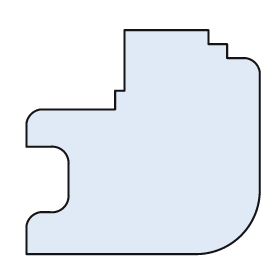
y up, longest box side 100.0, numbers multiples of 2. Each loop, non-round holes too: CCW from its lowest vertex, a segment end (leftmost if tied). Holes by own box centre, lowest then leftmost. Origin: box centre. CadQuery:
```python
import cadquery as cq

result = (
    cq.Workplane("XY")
    .moveTo(-50.0, -48.0)
    .lineTo(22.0, -48.0)
    .threePointArc((42.0, -40.0), (50.0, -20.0))
    .lineTo(50.0, 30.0)
    .threePointArc((48.0, 34.0), (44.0, 36.0))
    .lineTo(36.0, 36.0)
    .lineTo(36.0, 42.0)
    .lineTo(28.0, 42.0)
    .lineTo(28.0, 48.0)
    .lineTo(-8.0, 48.0)
    .lineTo(-8.0, 22.0)
    .lineTo(-12.0, 22.0)
    .lineTo(-12.0, 14.0)
    .lineTo(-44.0, 14.0)
    .threePointArc((-48.0, 12.0), (-50.0, 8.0))
    .lineTo(-50.0, -2.0)
    .lineTo(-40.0, -2.0)
    .threePointArc((-34.0, -4.0), (-32.0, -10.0))
    .lineTo(-32.0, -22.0)
    .threePointArc((-34.0, -28.0), (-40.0, -30.0))
    .lineTo(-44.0, -30.0)
    .threePointArc((-48.0, -32.0), (-50.0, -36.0))
    .close()
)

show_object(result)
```